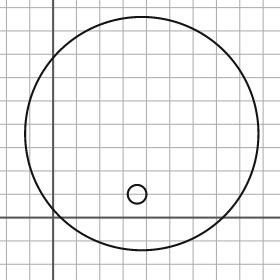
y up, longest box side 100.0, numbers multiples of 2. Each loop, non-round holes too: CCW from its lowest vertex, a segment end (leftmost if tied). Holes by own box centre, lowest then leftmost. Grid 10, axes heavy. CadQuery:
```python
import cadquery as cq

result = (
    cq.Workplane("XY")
    .moveTo(38.0, 36.0)
    .circle(50.0)
    .moveTo(36.0, 10.0)
    .circle(4.0)
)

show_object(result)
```